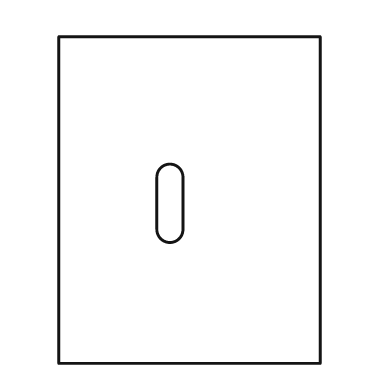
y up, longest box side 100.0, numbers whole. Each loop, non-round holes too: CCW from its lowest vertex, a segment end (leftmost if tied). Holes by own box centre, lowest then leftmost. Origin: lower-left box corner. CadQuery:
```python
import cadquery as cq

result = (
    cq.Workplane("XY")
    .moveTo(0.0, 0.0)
    .lineTo(80.0, 0.0)
    .lineTo(80.0, 100.0)
    .lineTo(0.0, 100.0)
    .close()
    .moveTo(30.0, 41.0)
    .threePointArc((34.0, 37.0), (38.0, 41.0))
    .lineTo(38.0, 57.0)
    .threePointArc((34.0, 61.0), (30.0, 57.0))
    .close()
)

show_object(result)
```